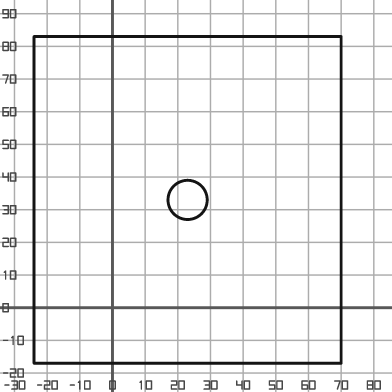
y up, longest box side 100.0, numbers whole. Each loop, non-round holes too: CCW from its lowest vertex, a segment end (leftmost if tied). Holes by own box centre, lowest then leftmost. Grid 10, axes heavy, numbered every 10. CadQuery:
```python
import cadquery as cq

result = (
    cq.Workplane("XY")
    .moveTo(-24.0, -17.0)
    .lineTo(70.0, -17.0)
    .lineTo(70.0, 83.0)
    .lineTo(-24.0, 83.0)
    .close()
    .moveTo(23.0, 33.0)
    .circle(6.0)
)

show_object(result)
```